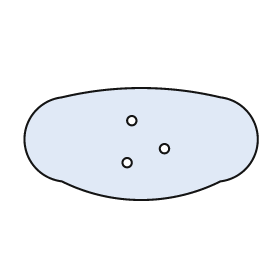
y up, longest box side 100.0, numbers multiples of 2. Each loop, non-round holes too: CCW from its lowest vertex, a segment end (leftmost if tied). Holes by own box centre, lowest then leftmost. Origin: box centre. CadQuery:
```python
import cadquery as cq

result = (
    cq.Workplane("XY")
    .moveTo(-34.0, -16.0)
    .threePointArc((0.0, -24.0), (34.0, -16.0))
    .threePointArc((50.0, 2.0), (34.0, 20.0))
    .threePointArc((0.0, 24.0), (-34.0, 20.0))
    .threePointArc((-50.0, 2.0), (-34.0, -16.0))
    .close()
    .moveTo(-6.0, -8.0)
    .circle(2.0)
    .moveTo(10.0, -2.0)
    .circle(2.0)
    .moveTo(-4.0, 10.0)
    .circle(2.0)
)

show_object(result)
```